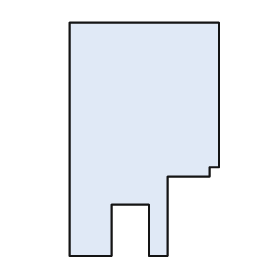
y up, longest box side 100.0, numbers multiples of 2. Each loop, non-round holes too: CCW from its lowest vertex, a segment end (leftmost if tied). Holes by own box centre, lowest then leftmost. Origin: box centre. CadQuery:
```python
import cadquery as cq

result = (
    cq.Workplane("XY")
    .moveTo(-32.0, -50.0)
    .lineTo(-14.0, -50.0)
    .lineTo(-14.0, -28.0)
    .lineTo(2.0, -28.0)
    .lineTo(2.0, -50.0)
    .lineTo(10.0, -50.0)
    .lineTo(10.0, -16.0)
    .lineTo(28.0, -16.0)
    .lineTo(28.0, -12.0)
    .lineTo(32.0, -12.0)
    .lineTo(32.0, 50.0)
    .lineTo(-32.0, 50.0)
    .close()
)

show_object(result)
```